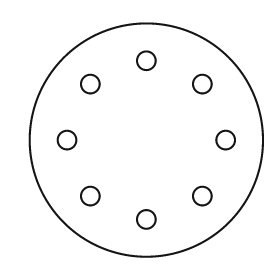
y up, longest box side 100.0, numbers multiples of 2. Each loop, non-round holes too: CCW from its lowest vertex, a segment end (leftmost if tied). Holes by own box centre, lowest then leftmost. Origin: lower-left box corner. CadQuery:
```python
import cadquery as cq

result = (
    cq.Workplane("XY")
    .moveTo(50.0, 50.0)
    .circle(50.0)
    .moveTo(50.0, 16.0)
    .circle(4.0)
    .moveTo(26.0, 26.0)
    .circle(4.0)
    .moveTo(74.0, 26.0)
    .circle(4.0)
    .moveTo(16.0, 50.0)
    .circle(4.0)
    .moveTo(84.0, 50.0)
    .circle(4.0)
    .moveTo(26.0, 74.0)
    .circle(4.0)
    .moveTo(74.0, 74.0)
    .circle(4.0)
    .moveTo(50.0, 84.0)
    .circle(4.0)
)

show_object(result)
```